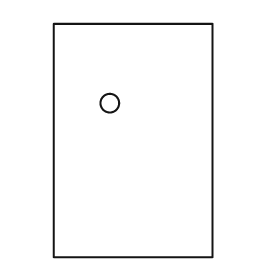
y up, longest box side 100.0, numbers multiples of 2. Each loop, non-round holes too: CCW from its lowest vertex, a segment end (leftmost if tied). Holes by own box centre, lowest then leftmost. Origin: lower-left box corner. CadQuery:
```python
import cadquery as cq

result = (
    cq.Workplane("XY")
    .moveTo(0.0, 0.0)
    .lineTo(68.0, 0.0)
    .lineTo(68.0, 100.0)
    .lineTo(0.0, 100.0)
    .close()
    .moveTo(24.0, 66.0)
    .circle(4.0)
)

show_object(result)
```